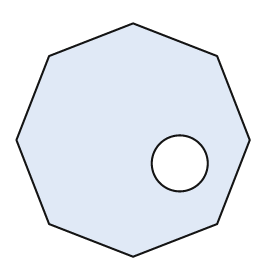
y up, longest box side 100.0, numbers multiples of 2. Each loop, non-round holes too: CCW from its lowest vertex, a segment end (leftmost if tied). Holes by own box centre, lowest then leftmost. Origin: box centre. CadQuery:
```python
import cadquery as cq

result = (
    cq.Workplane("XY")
    .moveTo(0.0, -50.0)
    .lineTo(36.0, -36.0)
    .lineTo(50.0, 0.0)
    .lineTo(36.0, 36.0)
    .lineTo(0.0, 50.0)
    .lineTo(-36.0, 36.0)
    .lineTo(-50.0, 0.0)
    .lineTo(-36.0, -36.0)
    .close()
    .moveTo(20.0, -10.0)
    .circle(12.0)
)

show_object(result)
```